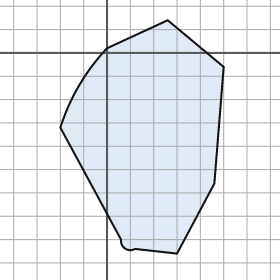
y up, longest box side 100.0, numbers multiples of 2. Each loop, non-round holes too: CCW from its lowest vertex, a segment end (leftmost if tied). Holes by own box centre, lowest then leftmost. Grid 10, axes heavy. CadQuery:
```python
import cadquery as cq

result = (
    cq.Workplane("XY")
    .moveTo(30.0, -86.0)
    .lineTo(46.0, -56.0)
    .lineTo(50.0, -6.0)
    .lineTo(26.0, 14.0)
    .lineTo(0.0, 2.0)
    .threePointArc((-12.0, -14.0), (-20.0, -32.0))
    .lineTo(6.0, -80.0)
    .threePointArc((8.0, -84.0), (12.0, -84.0))
    .close()
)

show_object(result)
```